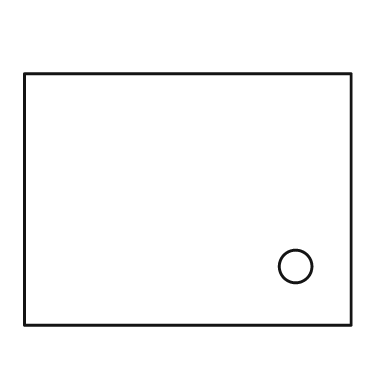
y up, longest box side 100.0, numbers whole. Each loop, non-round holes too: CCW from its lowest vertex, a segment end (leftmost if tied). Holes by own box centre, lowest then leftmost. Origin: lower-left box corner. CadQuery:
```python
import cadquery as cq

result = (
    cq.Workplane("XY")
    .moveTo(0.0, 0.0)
    .lineTo(100.0, 0.0)
    .lineTo(100.0, 77.0)
    .lineTo(0.0, 77.0)
    .close()
    .moveTo(83.0, 18.0)
    .circle(5.0)
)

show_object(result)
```